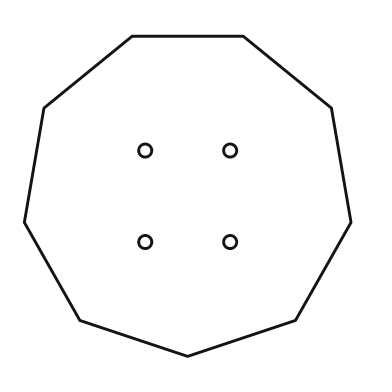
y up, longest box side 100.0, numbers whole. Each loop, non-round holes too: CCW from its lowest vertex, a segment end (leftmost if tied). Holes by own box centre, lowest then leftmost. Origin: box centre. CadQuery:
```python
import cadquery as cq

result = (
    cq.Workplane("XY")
    .moveTo(0.0, -49.0)
    .lineTo(33.0, -38.0)
    .lineTo(50.0, -8.0)
    .lineTo(44.0, 27.0)
    .lineTo(17.0, 49.0)
    .lineTo(-17.0, 49.0)
    .lineTo(-44.0, 27.0)
    .lineTo(-50.0, -8.0)
    .lineTo(-33.0, -38.0)
    .close()
    .moveTo(-13.0, -14.0)
    .circle(2.0)
    .moveTo(13.0, -14.0)
    .circle(2.0)
    .moveTo(-13.0, 14.0)
    .circle(2.0)
    .moveTo(13.0, 14.0)
    .circle(2.0)
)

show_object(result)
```